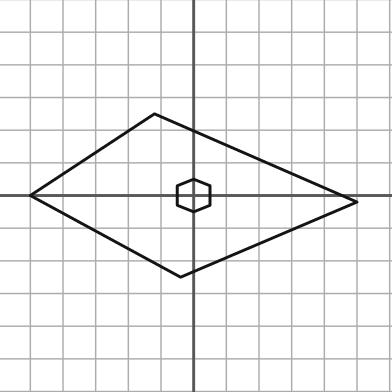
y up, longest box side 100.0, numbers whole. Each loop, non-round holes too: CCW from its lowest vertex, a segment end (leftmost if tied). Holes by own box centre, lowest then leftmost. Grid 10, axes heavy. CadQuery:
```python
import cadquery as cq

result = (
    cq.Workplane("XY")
    .moveTo(-4.0, -25.0)
    .lineTo(50.0, -2.0)
    .lineTo(-12.0, 25.0)
    .lineTo(-50.0, 0.0)
    .close()
    .moveTo(0.0, -5.0)
    .lineTo(5.0, -3.0)
    .lineTo(5.0, 3.0)
    .lineTo(0.0, 5.0)
    .lineTo(-5.0, 3.0)
    .lineTo(-5.0, -3.0)
    .close()
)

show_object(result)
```